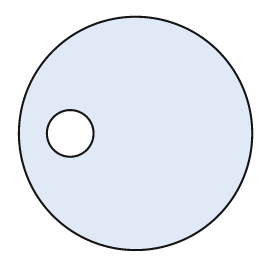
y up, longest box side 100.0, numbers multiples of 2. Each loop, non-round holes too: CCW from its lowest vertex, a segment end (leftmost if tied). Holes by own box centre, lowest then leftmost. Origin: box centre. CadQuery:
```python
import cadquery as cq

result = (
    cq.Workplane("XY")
    .moveTo(0.0, 0.0)
    .circle(50.0)
    .moveTo(-28.0, 0.0)
    .circle(10.0)
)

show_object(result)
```